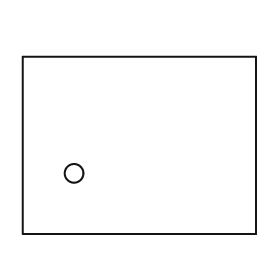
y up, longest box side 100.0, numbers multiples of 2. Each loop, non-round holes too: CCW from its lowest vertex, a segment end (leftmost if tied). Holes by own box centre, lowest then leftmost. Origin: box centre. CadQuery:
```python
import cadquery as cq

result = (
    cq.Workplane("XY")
    .moveTo(-50.0, -38.0)
    .lineTo(50.0, -38.0)
    .lineTo(50.0, 38.0)
    .lineTo(-50.0, 38.0)
    .close()
    .moveTo(-28.0, -12.0)
    .circle(4.0)
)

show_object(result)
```